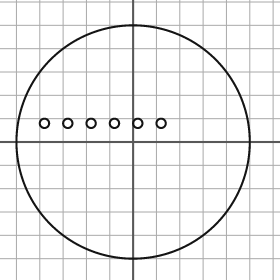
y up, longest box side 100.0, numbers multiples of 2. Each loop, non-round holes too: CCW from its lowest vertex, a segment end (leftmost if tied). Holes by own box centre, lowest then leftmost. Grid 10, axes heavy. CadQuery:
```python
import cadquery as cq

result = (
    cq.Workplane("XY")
    .moveTo(0.0, 0.0)
    .circle(50.0)
    .moveTo(-38.0, 8.0)
    .circle(2.0)
    .moveTo(-28.0, 8.0)
    .circle(2.0)
    .moveTo(-18.0, 8.0)
    .circle(2.0)
    .moveTo(-8.0, 8.0)
    .circle(2.0)
    .moveTo(2.0, 8.0)
    .circle(2.0)
    .moveTo(12.0, 8.0)
    .circle(2.0)
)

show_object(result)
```